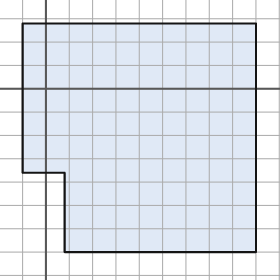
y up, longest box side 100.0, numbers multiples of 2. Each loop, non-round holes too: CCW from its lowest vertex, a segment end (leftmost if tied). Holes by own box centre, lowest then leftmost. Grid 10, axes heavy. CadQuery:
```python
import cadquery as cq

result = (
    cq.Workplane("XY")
    .moveTo(8.0, -70.0)
    .lineTo(90.0, -70.0)
    .lineTo(90.0, 28.0)
    .lineTo(-10.0, 28.0)
    .lineTo(-10.0, -36.0)
    .lineTo(8.0, -36.0)
    .close()
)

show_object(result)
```